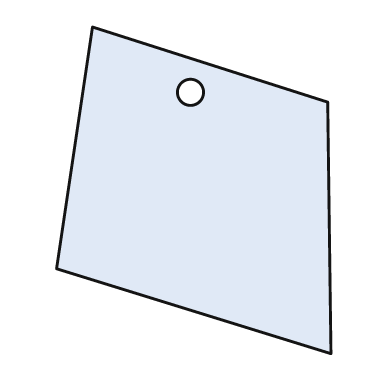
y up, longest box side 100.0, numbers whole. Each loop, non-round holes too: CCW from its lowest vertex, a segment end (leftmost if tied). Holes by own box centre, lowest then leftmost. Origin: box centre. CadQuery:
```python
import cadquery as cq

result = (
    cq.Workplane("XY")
    .moveTo(42.0, -50.0)
    .lineTo(41.0, 27.0)
    .lineTo(-31.0, 50.0)
    .lineTo(-42.0, -24.0)
    .close()
    .moveTo(-1.0, 30.0)
    .circle(4.0)
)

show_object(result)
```